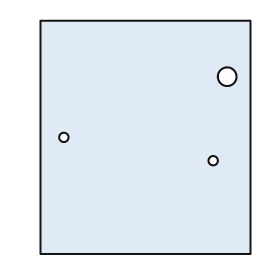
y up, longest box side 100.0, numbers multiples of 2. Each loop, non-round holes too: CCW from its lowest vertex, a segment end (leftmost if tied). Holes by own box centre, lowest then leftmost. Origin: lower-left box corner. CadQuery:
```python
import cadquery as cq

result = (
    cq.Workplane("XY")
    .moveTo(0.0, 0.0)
    .lineTo(90.0, 0.0)
    .lineTo(90.0, 100.0)
    .lineTo(0.0, 100.0)
    .close()
    .moveTo(74.0, 40.0)
    .circle(2.0)
    .moveTo(10.0, 50.0)
    .circle(2.0)
    .moveTo(80.0, 76.0)
    .circle(4.0)
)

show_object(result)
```